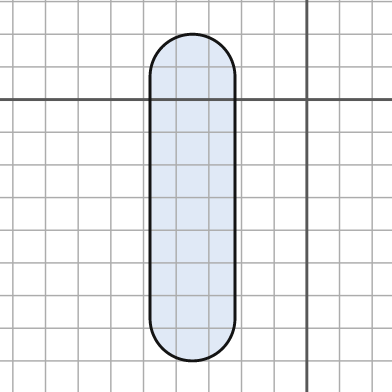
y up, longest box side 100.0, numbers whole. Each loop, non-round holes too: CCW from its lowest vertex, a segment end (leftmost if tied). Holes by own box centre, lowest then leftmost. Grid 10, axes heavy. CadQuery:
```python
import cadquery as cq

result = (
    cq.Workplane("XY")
    .moveTo(-48.0, -67.0)
    .threePointArc((-35.0, -80.0), (-22.0, -67.0))
    .lineTo(-22.0, 7.0)
    .threePointArc((-35.0, 20.0), (-48.0, 7.0))
    .close()
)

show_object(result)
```